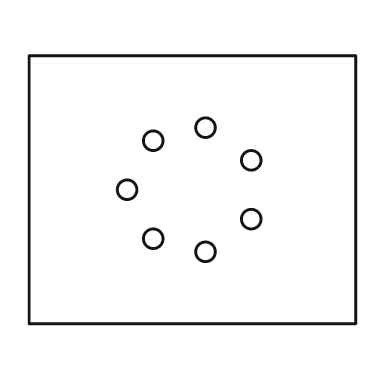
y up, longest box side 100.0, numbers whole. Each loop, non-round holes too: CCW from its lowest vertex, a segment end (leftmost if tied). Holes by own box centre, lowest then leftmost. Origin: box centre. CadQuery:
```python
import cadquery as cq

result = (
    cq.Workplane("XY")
    .moveTo(-50.0, -41.0)
    .lineTo(50.0, -41.0)
    .lineTo(50.0, 41.0)
    .lineTo(-50.0, 41.0)
    .close()
    .moveTo(4.0, -19.0)
    .circle(3.0)
    .moveTo(-12.0, -15.0)
    .circle(3.0)
    .moveTo(18.0, -9.0)
    .circle(3.0)
    .moveTo(-20.0, 0.0)
    .circle(3.0)
    .moveTo(18.0, 9.0)
    .circle(3.0)
    .moveTo(-12.0, 15.0)
    .circle(3.0)
    .moveTo(4.0, 19.0)
    .circle(3.0)
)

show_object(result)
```